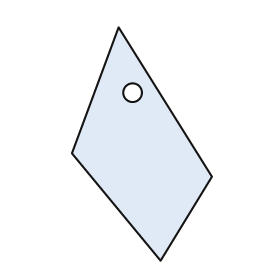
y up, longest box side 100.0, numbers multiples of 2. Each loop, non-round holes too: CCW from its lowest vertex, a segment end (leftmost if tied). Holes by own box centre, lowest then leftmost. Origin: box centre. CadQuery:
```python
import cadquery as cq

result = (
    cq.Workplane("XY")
    .moveTo(8.0, -50.0)
    .lineTo(30.0, -14.0)
    .lineTo(-10.0, 50.0)
    .lineTo(-30.0, -4.0)
    .close()
    .moveTo(-4.0, 22.0)
    .circle(4.0)
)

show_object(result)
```